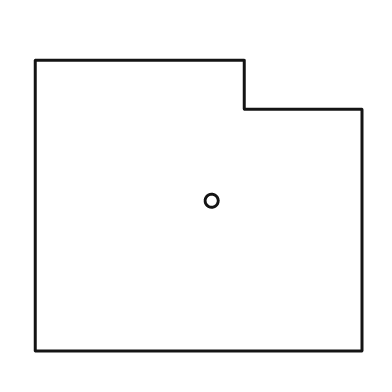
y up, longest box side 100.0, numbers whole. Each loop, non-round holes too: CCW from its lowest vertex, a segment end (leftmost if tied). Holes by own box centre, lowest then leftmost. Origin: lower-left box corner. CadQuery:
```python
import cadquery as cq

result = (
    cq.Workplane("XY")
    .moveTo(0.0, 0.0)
    .lineTo(100.0, 0.0)
    .lineTo(100.0, 74.0)
    .lineTo(64.0, 74.0)
    .lineTo(64.0, 89.0)
    .lineTo(0.0, 89.0)
    .close()
    .moveTo(54.0, 46.0)
    .circle(2.0)
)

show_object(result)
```